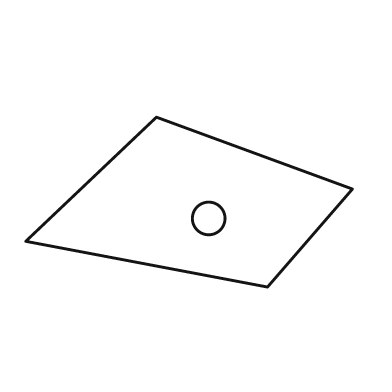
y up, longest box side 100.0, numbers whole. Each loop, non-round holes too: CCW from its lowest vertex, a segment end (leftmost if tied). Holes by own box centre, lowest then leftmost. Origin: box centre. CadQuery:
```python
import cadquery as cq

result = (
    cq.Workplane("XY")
    .moveTo(24.0, -26.0)
    .lineTo(50.0, 4.0)
    .lineTo(-10.0, 26.0)
    .lineTo(-50.0, -12.0)
    .close()
    .moveTo(6.0, -5.0)
    .circle(5.0)
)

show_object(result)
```